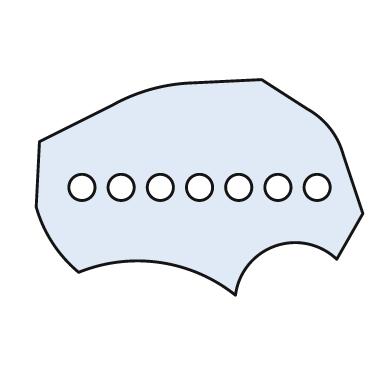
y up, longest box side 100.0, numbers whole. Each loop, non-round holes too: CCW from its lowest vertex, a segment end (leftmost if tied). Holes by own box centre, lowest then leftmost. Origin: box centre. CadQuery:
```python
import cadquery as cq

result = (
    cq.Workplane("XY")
    .moveTo(11.0, -33.0)
    .threePointArc((23.0, -18.0), (42.0, -22.0))
    .lineTo(50.0, -8.0)
    .lineTo(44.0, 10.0)
    .threePointArc((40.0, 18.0), (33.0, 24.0))
    .lineTo(19.0, 33.0)
    .lineTo(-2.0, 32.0)
    .threePointArc((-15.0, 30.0), (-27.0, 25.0))
    .lineTo(-49.0, 14.0)
    .lineTo(-50.0, -6.0)
    .threePointArc((-45.0, -17.0), (-37.0, -26.0))
    .threePointArc((-12.0, -23.0), (11.0, -33.0))
    .close()
    .moveTo(-36.0, 0.0)
    .circle(4.0)
    .moveTo(-24.0, 0.0)
    .circle(4.0)
    .moveTo(-12.0, 0.0)
    .circle(4.0)
    .moveTo(0.0, 0.0)
    .circle(4.0)
    .moveTo(12.0, 0.0)
    .circle(4.0)
    .moveTo(24.0, 0.0)
    .circle(4.0)
    .moveTo(36.0, 0.0)
    .circle(4.0)
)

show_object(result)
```